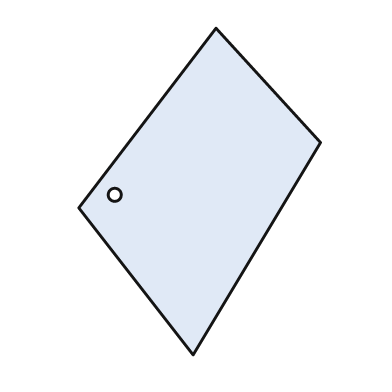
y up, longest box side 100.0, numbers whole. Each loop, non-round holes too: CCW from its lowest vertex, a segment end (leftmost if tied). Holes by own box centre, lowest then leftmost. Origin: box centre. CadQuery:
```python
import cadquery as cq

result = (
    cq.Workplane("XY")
    .moveTo(-2.0, -50.0)
    .lineTo(37.0, 15.0)
    .lineTo(5.0, 50.0)
    .lineTo(-37.0, -5.0)
    .close()
    .moveTo(-26.0, -1.0)
    .circle(2.0)
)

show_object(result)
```